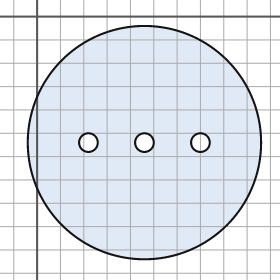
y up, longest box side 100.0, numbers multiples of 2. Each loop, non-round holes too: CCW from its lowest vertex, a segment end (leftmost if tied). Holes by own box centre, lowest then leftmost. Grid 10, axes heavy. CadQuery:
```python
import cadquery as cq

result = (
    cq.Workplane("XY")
    .moveTo(46.0, -54.0)
    .circle(50.0)
    .moveTo(22.0, -54.0)
    .circle(4.0)
    .moveTo(46.0, -54.0)
    .circle(4.0)
    .moveTo(70.0, -54.0)
    .circle(4.0)
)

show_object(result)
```